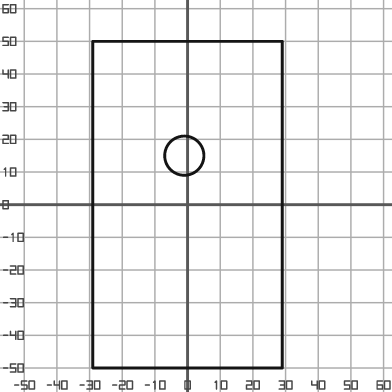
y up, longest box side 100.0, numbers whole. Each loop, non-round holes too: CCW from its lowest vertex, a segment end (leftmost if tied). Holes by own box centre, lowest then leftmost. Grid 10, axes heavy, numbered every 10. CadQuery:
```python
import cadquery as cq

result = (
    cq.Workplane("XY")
    .moveTo(-29.0, -50.0)
    .lineTo(29.0, -50.0)
    .lineTo(29.0, 50.0)
    .lineTo(-29.0, 50.0)
    .close()
    .moveTo(-1.0, 15.0)
    .circle(6.0)
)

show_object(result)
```